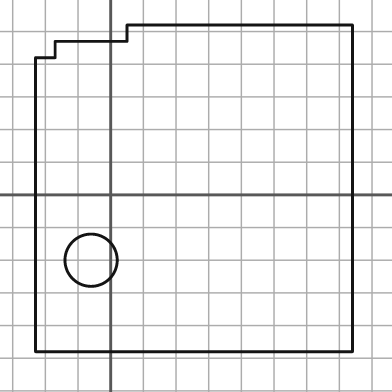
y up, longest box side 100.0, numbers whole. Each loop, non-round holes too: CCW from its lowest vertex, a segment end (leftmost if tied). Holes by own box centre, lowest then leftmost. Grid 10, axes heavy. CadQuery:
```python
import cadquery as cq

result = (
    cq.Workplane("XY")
    .moveTo(-23.0, -48.0)
    .lineTo(74.0, -48.0)
    .lineTo(74.0, 52.0)
    .lineTo(5.0, 52.0)
    .lineTo(5.0, 47.0)
    .lineTo(-17.0, 47.0)
    .lineTo(-17.0, 42.0)
    .lineTo(-23.0, 42.0)
    .close()
    .moveTo(-6.0, -20.0)
    .circle(8.0)
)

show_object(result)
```